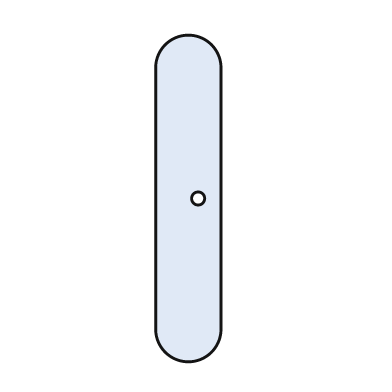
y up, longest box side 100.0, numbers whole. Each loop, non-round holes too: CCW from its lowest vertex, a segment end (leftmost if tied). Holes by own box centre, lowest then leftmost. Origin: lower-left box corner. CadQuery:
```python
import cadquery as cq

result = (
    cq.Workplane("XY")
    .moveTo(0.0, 10.0)
    .threePointArc((10.0, 0.0), (20.0, 10.0))
    .lineTo(20.0, 90.0)
    .threePointArc((10.0, 100.0), (0.0, 90.0))
    .close()
    .moveTo(13.0, 50.0)
    .circle(2.0)
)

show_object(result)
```